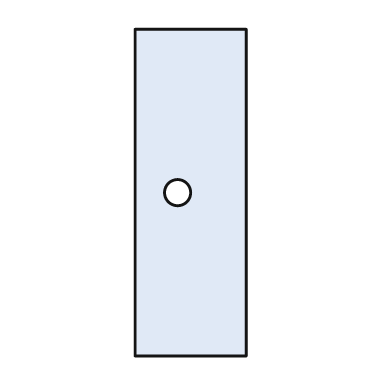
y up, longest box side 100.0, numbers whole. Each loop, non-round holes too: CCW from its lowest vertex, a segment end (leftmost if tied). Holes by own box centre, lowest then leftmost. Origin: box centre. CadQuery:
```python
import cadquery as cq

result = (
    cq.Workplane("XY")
    .moveTo(-17.0, -50.0)
    .lineTo(17.0, -50.0)
    .lineTo(17.0, 50.0)
    .lineTo(-17.0, 50.0)
    .close()
    .moveTo(-4.0, 0.0)
    .circle(4.0)
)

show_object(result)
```